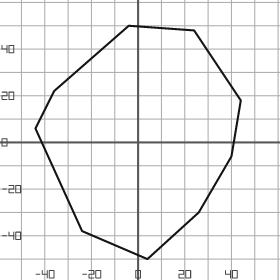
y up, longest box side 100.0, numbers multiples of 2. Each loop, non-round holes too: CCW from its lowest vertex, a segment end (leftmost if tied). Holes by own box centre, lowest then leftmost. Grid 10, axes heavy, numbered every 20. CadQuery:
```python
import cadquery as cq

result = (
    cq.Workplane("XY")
    .moveTo(4.0, -50.0)
    .lineTo(26.0, -30.0)
    .lineTo(40.0, -6.0)
    .lineTo(44.0, 18.0)
    .lineTo(24.0, 48.0)
    .lineTo(-4.0, 50.0)
    .lineTo(-36.0, 22.0)
    .lineTo(-44.0, 6.0)
    .lineTo(-24.0, -38.0)
    .close()
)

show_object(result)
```